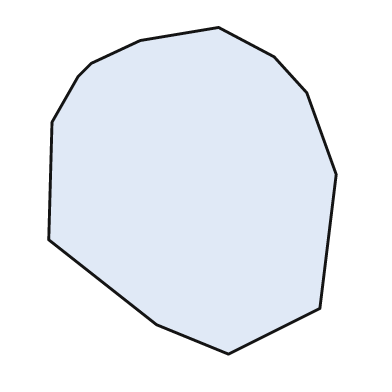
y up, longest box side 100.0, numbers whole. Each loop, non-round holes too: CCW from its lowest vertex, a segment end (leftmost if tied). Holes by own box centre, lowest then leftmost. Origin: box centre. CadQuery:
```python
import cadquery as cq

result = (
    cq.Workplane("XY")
    .moveTo(11.0, -50.0)
    .lineTo(39.0, -36.0)
    .lineTo(44.0, 5.0)
    .lineTo(35.0, 30.0)
    .lineTo(25.0, 41.0)
    .lineTo(8.0, 50.0)
    .lineTo(-16.0, 46.0)
    .lineTo(-31.0, 39.0)
    .lineTo(-35.0, 35.0)
    .lineTo(-43.0, 21.0)
    .lineTo(-44.0, -15.0)
    .lineTo(-11.0, -41.0)
    .close()
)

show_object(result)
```